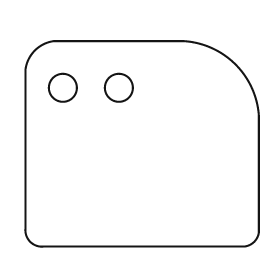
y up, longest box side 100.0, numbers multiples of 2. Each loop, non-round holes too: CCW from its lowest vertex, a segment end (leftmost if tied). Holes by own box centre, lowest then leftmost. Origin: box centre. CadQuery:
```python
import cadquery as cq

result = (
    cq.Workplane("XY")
    .moveTo(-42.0, -44.0)
    .lineTo(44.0, -44.0)
    .threePointArc((48.0, -42.0), (50.0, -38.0))
    .lineTo(50.0, 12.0)
    .threePointArc((40.0, 34.0), (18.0, 44.0))
    .lineTo(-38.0, 44.0)
    .threePointArc((-46.0, 40.0), (-50.0, 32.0))
    .lineTo(-50.0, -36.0)
    .threePointArc((-48.0, -42.0), (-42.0, -44.0))
    .close()
    .moveTo(-34.0, 24.0)
    .circle(6.0)
    .moveTo(-10.0, 24.0)
    .circle(6.0)
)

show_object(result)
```